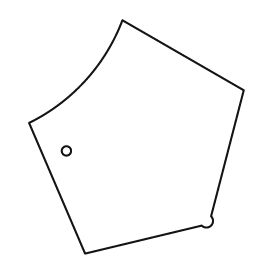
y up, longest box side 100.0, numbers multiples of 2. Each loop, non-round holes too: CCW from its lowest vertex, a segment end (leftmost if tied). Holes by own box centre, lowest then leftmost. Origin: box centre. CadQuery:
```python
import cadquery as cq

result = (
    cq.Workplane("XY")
    .moveTo(-22.0, -50.0)
    .lineTo(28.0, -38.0)
    .threePointArc((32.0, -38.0), (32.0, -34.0))
    .lineTo(46.0, 20.0)
    .lineTo(-6.0, 50.0)
    .threePointArc((-22.0, 24.0), (-46.0, 6.0))
    .close()
    .moveTo(-30.0, -6.0)
    .circle(2.0)
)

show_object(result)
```